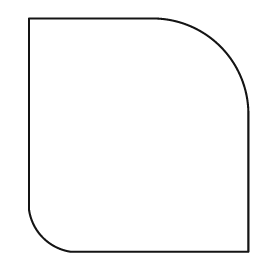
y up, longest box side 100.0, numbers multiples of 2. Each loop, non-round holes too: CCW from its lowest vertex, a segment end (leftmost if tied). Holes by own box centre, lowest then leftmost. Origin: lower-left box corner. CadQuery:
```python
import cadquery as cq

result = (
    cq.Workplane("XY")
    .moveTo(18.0, 0.0)
    .lineTo(94.0, 0.0)
    .lineTo(94.0, 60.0)
    .threePointArc((82.0, 88.0), (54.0, 100.0))
    .lineTo(0.0, 100.0)
    .lineTo(0.0, 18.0)
    .threePointArc((6.0, 6.0), (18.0, 0.0))
    .close()
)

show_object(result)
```